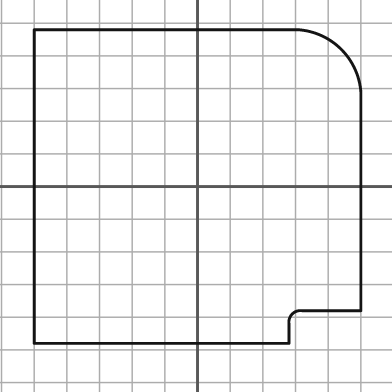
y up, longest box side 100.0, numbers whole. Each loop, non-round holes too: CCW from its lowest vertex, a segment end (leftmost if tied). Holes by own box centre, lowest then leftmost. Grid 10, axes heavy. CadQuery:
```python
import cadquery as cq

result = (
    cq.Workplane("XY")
    .moveTo(-50.0, -48.0)
    .lineTo(28.0, -48.0)
    .lineTo(28.0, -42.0)
    .threePointArc((29.0, -39.0), (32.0, -38.0))
    .lineTo(50.0, -38.0)
    .lineTo(50.0, 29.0)
    .threePointArc((44.0, 42.0), (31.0, 48.0))
    .lineTo(-50.0, 48.0)
    .close()
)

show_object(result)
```